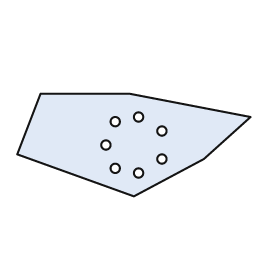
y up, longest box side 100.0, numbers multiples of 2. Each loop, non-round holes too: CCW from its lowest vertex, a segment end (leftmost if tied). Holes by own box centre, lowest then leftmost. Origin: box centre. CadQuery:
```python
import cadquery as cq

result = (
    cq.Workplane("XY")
    .moveTo(0.0, -22.0)
    .lineTo(30.0, -6.0)
    .lineTo(50.0, 12.0)
    .lineTo(-2.0, 22.0)
    .lineTo(-40.0, 22.0)
    .lineTo(-50.0, -4.0)
    .close()
    .moveTo(2.0, -12.0)
    .circle(2.0)
    .moveTo(-8.0, -10.0)
    .circle(2.0)
    .moveTo(12.0, -6.0)
    .circle(2.0)
    .moveTo(-12.0, 0.0)
    .circle(2.0)
    .moveTo(12.0, 6.0)
    .circle(2.0)
    .moveTo(-8.0, 10.0)
    .circle(2.0)
    .moveTo(2.0, 12.0)
    .circle(2.0)
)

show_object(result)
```